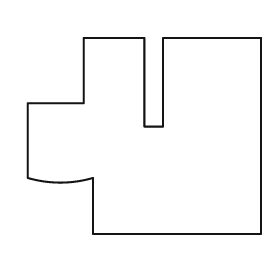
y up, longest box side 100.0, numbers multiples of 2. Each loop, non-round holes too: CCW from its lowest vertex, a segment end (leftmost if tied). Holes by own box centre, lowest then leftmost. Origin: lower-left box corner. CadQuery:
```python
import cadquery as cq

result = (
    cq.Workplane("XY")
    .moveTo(28.0, 0.0)
    .lineTo(100.0, 0.0)
    .lineTo(100.0, 84.0)
    .lineTo(58.0, 84.0)
    .lineTo(58.0, 46.0)
    .lineTo(50.0, 46.0)
    .lineTo(50.0, 84.0)
    .lineTo(24.0, 84.0)
    .lineTo(24.0, 56.0)
    .lineTo(0.0, 56.0)
    .lineTo(0.0, 24.0)
    .threePointArc((14.0, 22.0), (28.0, 24.0))
    .close()
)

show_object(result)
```